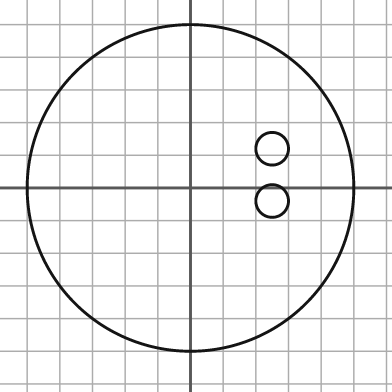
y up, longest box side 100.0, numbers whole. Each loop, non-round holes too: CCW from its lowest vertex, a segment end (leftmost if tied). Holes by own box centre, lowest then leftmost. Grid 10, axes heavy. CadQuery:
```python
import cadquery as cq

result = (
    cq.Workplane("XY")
    .moveTo(0.0, 0.0)
    .circle(50.0)
    .moveTo(25.0, -4.0)
    .circle(5.0)
    .moveTo(25.0, 12.0)
    .circle(5.0)
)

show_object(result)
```